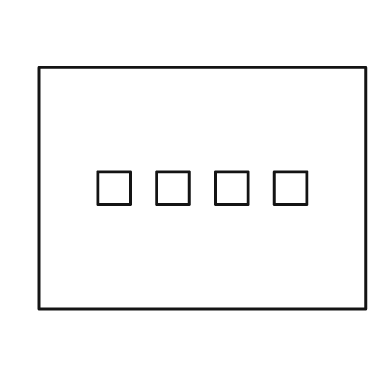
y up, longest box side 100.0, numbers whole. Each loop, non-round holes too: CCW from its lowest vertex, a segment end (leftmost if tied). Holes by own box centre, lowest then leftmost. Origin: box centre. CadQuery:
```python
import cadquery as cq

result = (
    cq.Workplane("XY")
    .moveTo(-50.0, -37.0)
    .lineTo(50.0, -37.0)
    .lineTo(50.0, 37.0)
    .lineTo(-50.0, 37.0)
    .close()
    .moveTo(-32.0, -5.0)
    .lineTo(-22.0, -5.0)
    .lineTo(-22.0, 5.0)
    .lineTo(-32.0, 5.0)
    .close()
    .moveTo(-14.0, -5.0)
    .lineTo(-4.0, -5.0)
    .lineTo(-4.0, 5.0)
    .lineTo(-14.0, 5.0)
    .close()
    .moveTo(4.0, -5.0)
    .lineTo(14.0, -5.0)
    .lineTo(14.0, 5.0)
    .lineTo(4.0, 5.0)
    .close()
    .moveTo(22.0, -5.0)
    .lineTo(32.0, -5.0)
    .lineTo(32.0, 5.0)
    .lineTo(22.0, 5.0)
    .close()
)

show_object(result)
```